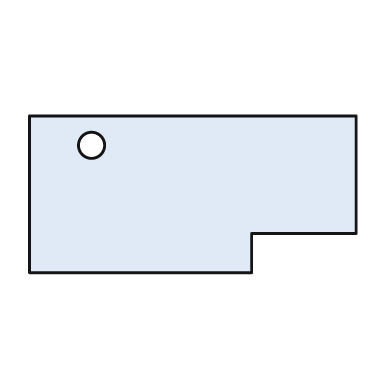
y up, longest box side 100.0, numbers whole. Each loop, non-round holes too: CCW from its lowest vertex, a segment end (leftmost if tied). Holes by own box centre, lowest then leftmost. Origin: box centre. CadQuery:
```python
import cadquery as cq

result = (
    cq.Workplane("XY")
    .moveTo(-50.0, -24.0)
    .lineTo(18.0, -24.0)
    .lineTo(18.0, -12.0)
    .lineTo(50.0, -12.0)
    .lineTo(50.0, 24.0)
    .lineTo(-50.0, 24.0)
    .close()
    .moveTo(-31.0, 15.0)
    .circle(4.0)
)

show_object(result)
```